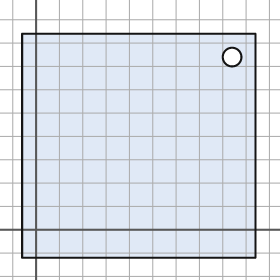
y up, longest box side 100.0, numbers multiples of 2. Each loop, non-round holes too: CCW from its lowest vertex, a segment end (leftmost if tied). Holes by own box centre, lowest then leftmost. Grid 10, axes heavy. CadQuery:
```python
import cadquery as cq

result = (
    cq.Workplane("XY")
    .moveTo(-6.0, -12.0)
    .lineTo(94.0, -12.0)
    .lineTo(94.0, 84.0)
    .lineTo(-6.0, 84.0)
    .close()
    .moveTo(84.0, 74.0)
    .circle(4.0)
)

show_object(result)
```